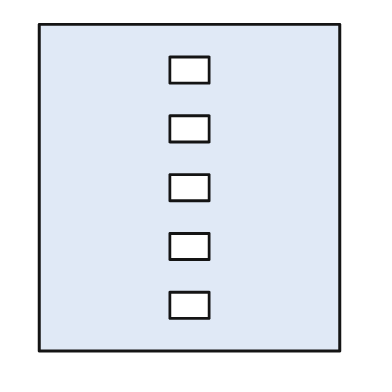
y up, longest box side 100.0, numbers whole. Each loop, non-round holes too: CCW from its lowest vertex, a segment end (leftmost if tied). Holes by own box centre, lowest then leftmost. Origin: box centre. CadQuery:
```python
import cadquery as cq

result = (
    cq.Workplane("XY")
    .moveTo(-46.0, -50.0)
    .lineTo(46.0, -50.0)
    .lineTo(46.0, 50.0)
    .lineTo(-46.0, 50.0)
    .close()
    .moveTo(-6.0, -40.0)
    .lineTo(6.0, -40.0)
    .lineTo(6.0, -32.0)
    .lineTo(-6.0, -32.0)
    .close()
    .moveTo(-6.0, -22.0)
    .lineTo(6.0, -22.0)
    .lineTo(6.0, -14.0)
    .lineTo(-6.0, -14.0)
    .close()
    .moveTo(-6.0, -4.0)
    .lineTo(6.0, -4.0)
    .lineTo(6.0, 4.0)
    .lineTo(-6.0, 4.0)
    .close()
    .moveTo(-6.0, 14.0)
    .lineTo(6.0, 14.0)
    .lineTo(6.0, 22.0)
    .lineTo(-6.0, 22.0)
    .close()
    .moveTo(-6.0, 32.0)
    .lineTo(6.0, 32.0)
    .lineTo(6.0, 40.0)
    .lineTo(-6.0, 40.0)
    .close()
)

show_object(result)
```